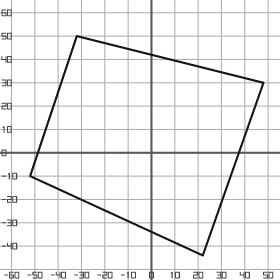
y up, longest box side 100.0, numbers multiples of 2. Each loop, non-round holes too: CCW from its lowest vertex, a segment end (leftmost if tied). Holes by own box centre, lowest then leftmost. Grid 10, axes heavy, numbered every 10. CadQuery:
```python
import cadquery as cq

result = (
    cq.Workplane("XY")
    .moveTo(22.0, -44.0)
    .lineTo(48.0, 30.0)
    .lineTo(-32.0, 50.0)
    .lineTo(-52.0, -10.0)
    .close()
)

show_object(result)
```